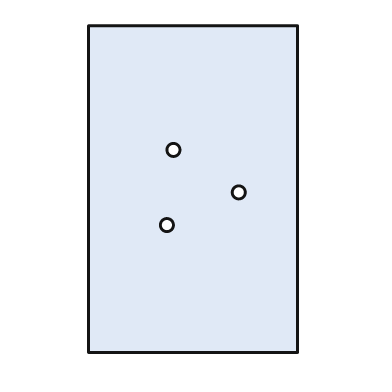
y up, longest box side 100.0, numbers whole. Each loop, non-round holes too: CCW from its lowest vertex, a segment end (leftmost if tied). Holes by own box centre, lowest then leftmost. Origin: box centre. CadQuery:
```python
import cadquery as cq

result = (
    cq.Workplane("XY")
    .moveTo(-32.0, -50.0)
    .lineTo(32.0, -50.0)
    .lineTo(32.0, 50.0)
    .lineTo(-32.0, 50.0)
    .close()
    .moveTo(-8.0, -11.0)
    .circle(2.0)
    .moveTo(14.0, -1.0)
    .circle(2.0)
    .moveTo(-6.0, 12.0)
    .circle(2.0)
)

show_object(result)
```